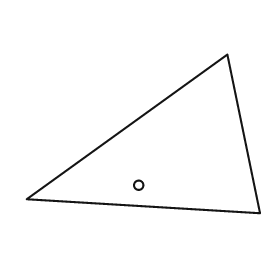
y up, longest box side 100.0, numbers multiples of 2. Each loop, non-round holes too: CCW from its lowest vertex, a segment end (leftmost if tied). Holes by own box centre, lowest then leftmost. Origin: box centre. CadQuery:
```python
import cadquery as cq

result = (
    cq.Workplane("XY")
    .moveTo(50.0, -34.0)
    .lineTo(36.0, 34.0)
    .lineTo(-50.0, -28.0)
    .close()
    .moveTo(-2.0, -22.0)
    .circle(2.0)
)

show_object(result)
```